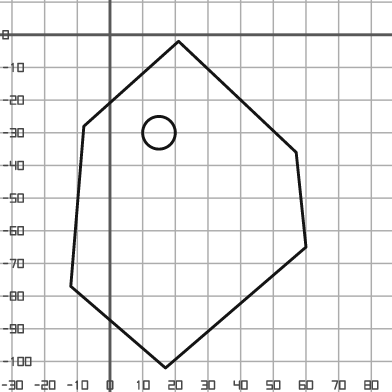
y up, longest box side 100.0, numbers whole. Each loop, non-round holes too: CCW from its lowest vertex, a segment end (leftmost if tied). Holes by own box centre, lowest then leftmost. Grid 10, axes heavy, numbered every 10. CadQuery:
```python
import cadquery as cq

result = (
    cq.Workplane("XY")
    .moveTo(17.0, -102.0)
    .lineTo(60.0, -65.0)
    .lineTo(57.0, -36.0)
    .lineTo(21.0, -2.0)
    .lineTo(-8.0, -28.0)
    .lineTo(-12.0, -77.0)
    .close()
    .moveTo(15.0, -30.0)
    .circle(5.0)
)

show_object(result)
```